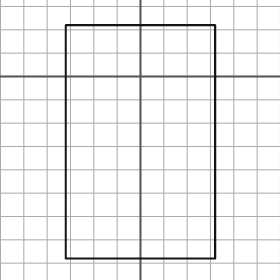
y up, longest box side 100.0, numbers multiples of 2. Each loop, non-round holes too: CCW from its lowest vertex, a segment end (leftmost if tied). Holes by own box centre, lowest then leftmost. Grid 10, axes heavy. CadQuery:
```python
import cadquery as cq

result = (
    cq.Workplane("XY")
    .moveTo(-32.0, -78.0)
    .lineTo(32.0, -78.0)
    .lineTo(32.0, 22.0)
    .lineTo(-32.0, 22.0)
    .close()
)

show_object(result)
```